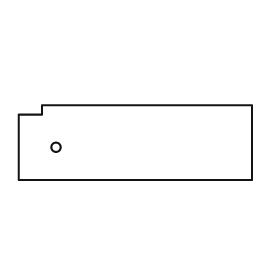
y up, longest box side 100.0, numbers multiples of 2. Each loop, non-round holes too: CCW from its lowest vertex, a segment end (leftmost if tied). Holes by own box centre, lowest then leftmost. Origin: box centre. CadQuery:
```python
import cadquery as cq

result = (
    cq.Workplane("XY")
    .moveTo(-50.0, -16.0)
    .lineTo(50.0, -16.0)
    .lineTo(50.0, 16.0)
    .lineTo(-40.0, 16.0)
    .lineTo(-40.0, 12.0)
    .lineTo(-50.0, 12.0)
    .close()
    .moveTo(-34.0, -2.0)
    .circle(2.0)
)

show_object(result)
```